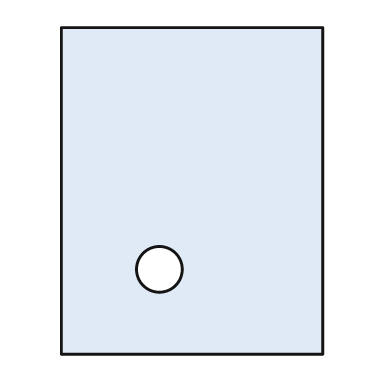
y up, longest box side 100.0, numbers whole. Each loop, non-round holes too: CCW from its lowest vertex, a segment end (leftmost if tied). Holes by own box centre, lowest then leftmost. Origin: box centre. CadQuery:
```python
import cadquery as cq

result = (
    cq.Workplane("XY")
    .moveTo(-40.0, -50.0)
    .lineTo(40.0, -50.0)
    .lineTo(40.0, 50.0)
    .lineTo(-40.0, 50.0)
    .close()
    .moveTo(-10.0, -24.0)
    .circle(7.0)
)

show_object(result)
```